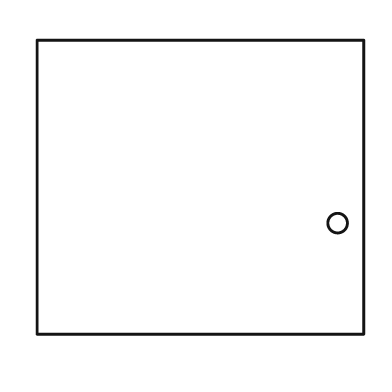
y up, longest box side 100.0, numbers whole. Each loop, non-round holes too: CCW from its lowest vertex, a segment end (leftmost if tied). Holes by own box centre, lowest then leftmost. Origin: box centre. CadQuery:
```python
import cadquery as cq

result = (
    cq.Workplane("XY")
    .moveTo(-50.0, -45.0)
    .lineTo(50.0, -45.0)
    .lineTo(50.0, 45.0)
    .lineTo(-50.0, 45.0)
    .close()
    .moveTo(42.0, -11.0)
    .circle(3.0)
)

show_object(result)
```